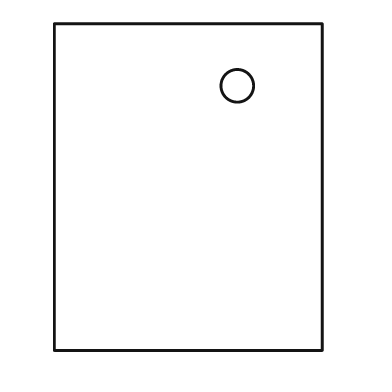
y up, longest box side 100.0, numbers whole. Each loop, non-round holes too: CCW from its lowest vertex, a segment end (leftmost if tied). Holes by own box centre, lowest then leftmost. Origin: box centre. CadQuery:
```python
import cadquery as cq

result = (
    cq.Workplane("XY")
    .moveTo(-41.0, -50.0)
    .lineTo(41.0, -50.0)
    .lineTo(41.0, 50.0)
    .lineTo(-41.0, 50.0)
    .close()
    .moveTo(15.0, 31.0)
    .circle(5.0)
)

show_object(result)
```